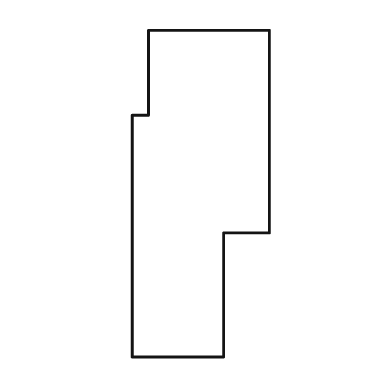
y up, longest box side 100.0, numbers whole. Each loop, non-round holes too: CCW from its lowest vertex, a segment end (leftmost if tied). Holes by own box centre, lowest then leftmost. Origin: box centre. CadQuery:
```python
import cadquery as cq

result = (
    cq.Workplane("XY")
    .moveTo(-21.0, -50.0)
    .lineTo(7.0, -50.0)
    .lineTo(7.0, -12.0)
    .lineTo(21.0, -12.0)
    .lineTo(21.0, 50.0)
    .lineTo(-16.0, 50.0)
    .lineTo(-16.0, 24.0)
    .lineTo(-21.0, 24.0)
    .close()
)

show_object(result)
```